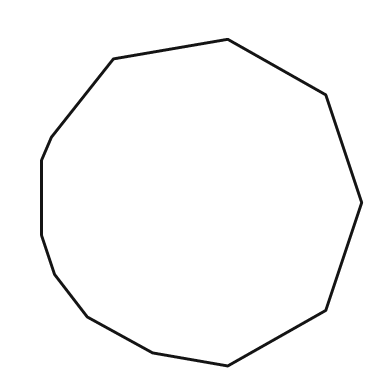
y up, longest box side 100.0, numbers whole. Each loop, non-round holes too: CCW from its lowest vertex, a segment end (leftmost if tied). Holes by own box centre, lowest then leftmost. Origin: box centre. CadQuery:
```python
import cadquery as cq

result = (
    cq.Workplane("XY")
    .moveTo(8.0, -50.0)
    .lineTo(38.0, -33.0)
    .lineTo(49.0, 0.0)
    .lineTo(38.0, 33.0)
    .lineTo(8.0, 50.0)
    .lineTo(-27.0, 44.0)
    .lineTo(-46.0, 20.0)
    .lineTo(-49.0, 13.0)
    .lineTo(-49.0, -10.0)
    .lineTo(-45.0, -22.0)
    .lineTo(-35.0, -35.0)
    .lineTo(-15.0, -46.0)
    .close()
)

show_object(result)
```